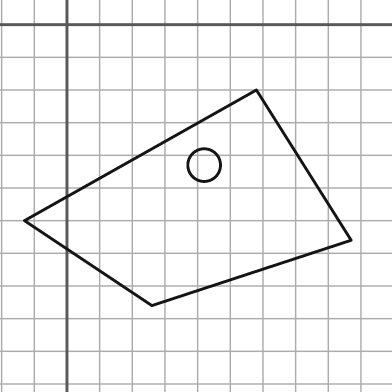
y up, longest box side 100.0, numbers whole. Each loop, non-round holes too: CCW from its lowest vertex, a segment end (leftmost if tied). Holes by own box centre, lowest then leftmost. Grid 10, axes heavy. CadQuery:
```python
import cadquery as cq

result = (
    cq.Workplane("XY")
    .moveTo(26.0, -86.0)
    .lineTo(87.0, -66.0)
    .lineTo(58.0, -20.0)
    .lineTo(-13.0, -60.0)
    .close()
    .moveTo(42.0, -43.0)
    .circle(5.0)
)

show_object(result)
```